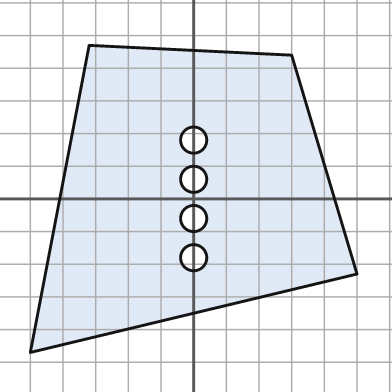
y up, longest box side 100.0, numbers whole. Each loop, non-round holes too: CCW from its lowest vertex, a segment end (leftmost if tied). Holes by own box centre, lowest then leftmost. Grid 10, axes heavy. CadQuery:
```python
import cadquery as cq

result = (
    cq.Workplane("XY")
    .moveTo(-50.0, -47.0)
    .lineTo(50.0, -23.0)
    .lineTo(30.0, 44.0)
    .lineTo(-32.0, 47.0)
    .close()
    .moveTo(0.0, -18.0)
    .circle(4.0)
    .moveTo(0.0, -6.0)
    .circle(4.0)
    .moveTo(0.0, 6.0)
    .circle(4.0)
    .moveTo(0.0, 18.0)
    .circle(4.0)
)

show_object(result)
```